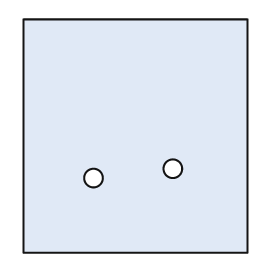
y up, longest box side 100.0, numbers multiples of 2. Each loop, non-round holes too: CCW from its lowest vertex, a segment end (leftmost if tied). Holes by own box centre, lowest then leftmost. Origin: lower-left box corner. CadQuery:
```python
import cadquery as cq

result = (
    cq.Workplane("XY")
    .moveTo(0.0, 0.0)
    .lineTo(96.0, 0.0)
    .lineTo(96.0, 100.0)
    .lineTo(0.0, 100.0)
    .close()
    .moveTo(30.0, 32.0)
    .circle(4.0)
    .moveTo(64.0, 36.0)
    .circle(4.0)
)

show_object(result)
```